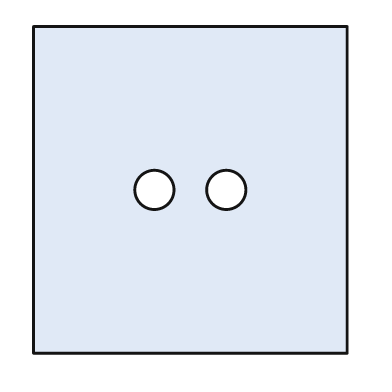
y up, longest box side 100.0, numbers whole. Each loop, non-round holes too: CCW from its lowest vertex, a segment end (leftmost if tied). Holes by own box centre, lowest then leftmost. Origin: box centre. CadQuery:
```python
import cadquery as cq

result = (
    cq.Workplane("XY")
    .moveTo(-48.0, -50.0)
    .lineTo(48.0, -50.0)
    .lineTo(48.0, 50.0)
    .lineTo(-48.0, 50.0)
    .close()
    .moveTo(-11.0, 0.0)
    .circle(6.0)
    .moveTo(11.0, 0.0)
    .circle(6.0)
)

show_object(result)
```